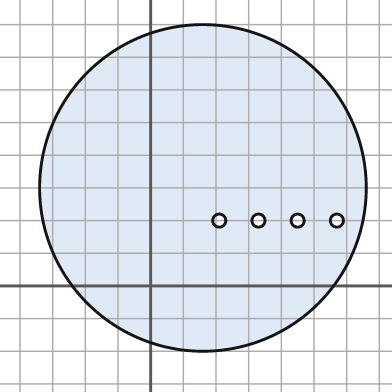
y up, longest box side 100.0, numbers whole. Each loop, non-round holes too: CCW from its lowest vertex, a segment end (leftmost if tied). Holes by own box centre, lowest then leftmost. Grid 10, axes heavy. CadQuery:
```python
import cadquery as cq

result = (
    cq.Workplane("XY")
    .moveTo(16.0, 30.0)
    .circle(50.0)
    .moveTo(21.0, 20.0)
    .circle(2.0)
    .moveTo(33.0, 20.0)
    .circle(2.0)
    .moveTo(45.0, 20.0)
    .circle(2.0)
    .moveTo(57.0, 20.0)
    .circle(2.0)
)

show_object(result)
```